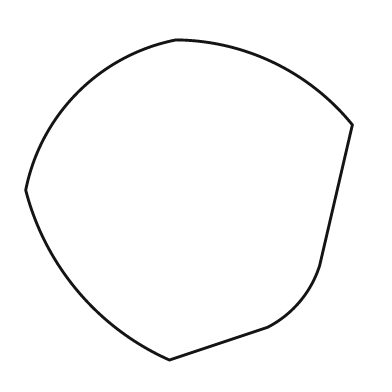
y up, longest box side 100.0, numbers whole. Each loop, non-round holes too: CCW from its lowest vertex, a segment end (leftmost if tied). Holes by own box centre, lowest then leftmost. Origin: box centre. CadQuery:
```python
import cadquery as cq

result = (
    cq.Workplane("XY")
    .moveTo(-6.0, -49.0)
    .lineTo(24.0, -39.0)
    .threePointArc((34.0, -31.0), (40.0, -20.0))
    .lineTo(50.0, 23.0)
    .threePointArc((26.0, 42.0), (-4.0, 49.0))
    .threePointArc((-34.0, 33.0), (-50.0, 3.0))
    .threePointArc((-34.0, -28.0), (-6.0, -49.0))
    .close()
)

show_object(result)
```